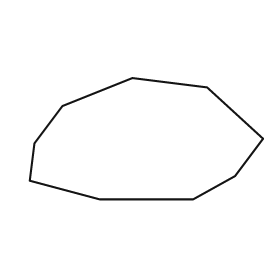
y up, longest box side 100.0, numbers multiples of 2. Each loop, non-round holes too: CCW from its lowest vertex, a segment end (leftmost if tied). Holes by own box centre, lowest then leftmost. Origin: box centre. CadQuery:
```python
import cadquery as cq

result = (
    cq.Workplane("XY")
    .moveTo(-20.0, -26.0)
    .lineTo(20.0, -26.0)
    .lineTo(38.0, -16.0)
    .lineTo(50.0, 0.0)
    .lineTo(26.0, 22.0)
    .lineTo(-6.0, 26.0)
    .lineTo(-36.0, 14.0)
    .lineTo(-48.0, -2.0)
    .lineTo(-50.0, -18.0)
    .close()
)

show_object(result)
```